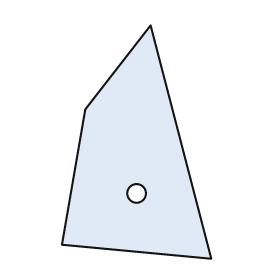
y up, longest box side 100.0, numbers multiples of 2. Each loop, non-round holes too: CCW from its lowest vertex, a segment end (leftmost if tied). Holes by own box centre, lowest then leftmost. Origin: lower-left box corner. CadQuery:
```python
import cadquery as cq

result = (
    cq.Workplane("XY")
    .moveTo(64.0, 0.0)
    .lineTo(38.0, 100.0)
    .lineTo(10.0, 64.0)
    .lineTo(0.0, 6.0)
    .close()
    .moveTo(32.0, 28.0)
    .circle(4.0)
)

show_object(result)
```